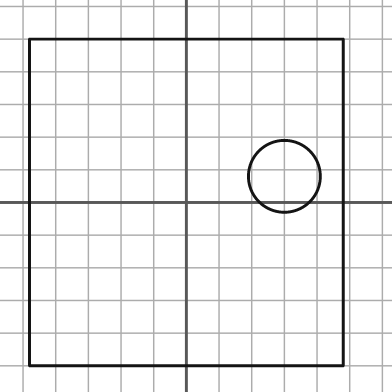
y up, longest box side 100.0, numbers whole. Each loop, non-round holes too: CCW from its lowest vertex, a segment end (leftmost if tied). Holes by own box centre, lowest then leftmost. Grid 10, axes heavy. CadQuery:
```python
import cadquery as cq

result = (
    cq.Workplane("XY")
    .moveTo(-48.0, -50.0)
    .lineTo(48.0, -50.0)
    .lineTo(48.0, 50.0)
    .lineTo(-48.0, 50.0)
    .close()
    .moveTo(30.0, 8.0)
    .circle(11.0)
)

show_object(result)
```